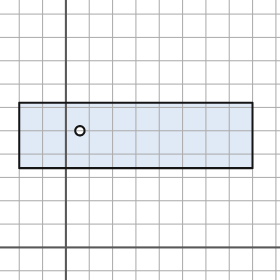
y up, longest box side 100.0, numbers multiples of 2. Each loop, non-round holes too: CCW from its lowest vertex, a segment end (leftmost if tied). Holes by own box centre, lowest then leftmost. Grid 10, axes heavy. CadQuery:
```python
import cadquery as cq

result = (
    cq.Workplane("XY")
    .moveTo(-20.0, 34.0)
    .lineTo(80.0, 34.0)
    .lineTo(80.0, 62.0)
    .lineTo(-20.0, 62.0)
    .close()
    .moveTo(6.0, 50.0)
    .circle(2.0)
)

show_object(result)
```